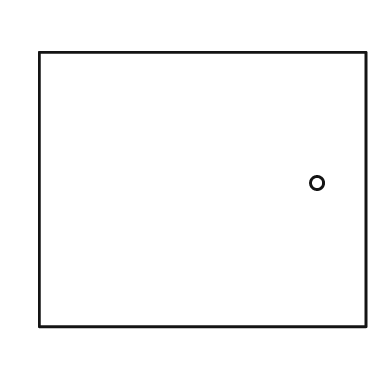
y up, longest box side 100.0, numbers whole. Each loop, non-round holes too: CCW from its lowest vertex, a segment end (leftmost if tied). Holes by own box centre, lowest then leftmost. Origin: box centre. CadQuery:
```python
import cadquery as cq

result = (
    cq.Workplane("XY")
    .moveTo(-50.0, -42.0)
    .lineTo(50.0, -42.0)
    .lineTo(50.0, 42.0)
    .lineTo(-50.0, 42.0)
    .close()
    .moveTo(35.0, 2.0)
    .circle(2.0)
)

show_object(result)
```